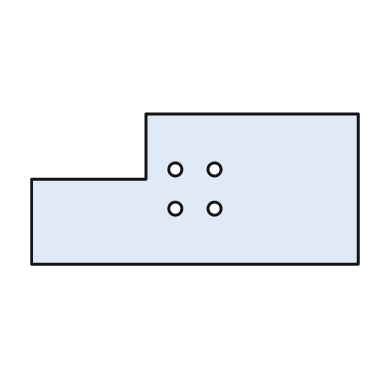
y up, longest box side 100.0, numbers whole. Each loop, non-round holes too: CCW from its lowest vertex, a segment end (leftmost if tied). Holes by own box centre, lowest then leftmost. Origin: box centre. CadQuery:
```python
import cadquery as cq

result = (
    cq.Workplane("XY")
    .moveTo(-50.0, -23.0)
    .lineTo(50.0, -23.0)
    .lineTo(50.0, 23.0)
    .lineTo(-15.0, 23.0)
    .lineTo(-15.0, 3.0)
    .lineTo(-50.0, 3.0)
    .close()
    .moveTo(-6.0, -6.0)
    .circle(2.0)
    .moveTo(6.0, -6.0)
    .circle(2.0)
    .moveTo(-6.0, 6.0)
    .circle(2.0)
    .moveTo(6.0, 6.0)
    .circle(2.0)
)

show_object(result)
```